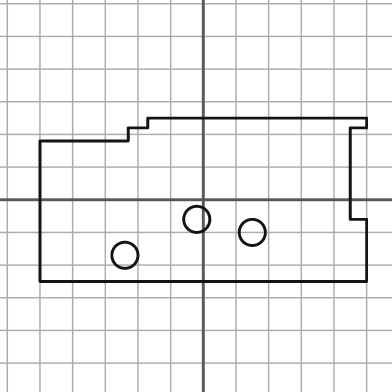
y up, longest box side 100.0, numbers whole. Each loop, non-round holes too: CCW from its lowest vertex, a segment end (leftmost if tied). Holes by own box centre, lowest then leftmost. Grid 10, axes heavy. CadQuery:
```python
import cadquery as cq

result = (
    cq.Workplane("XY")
    .moveTo(-50.0, -25.0)
    .lineTo(50.0, -25.0)
    .lineTo(50.0, -6.0)
    .lineTo(45.0, -6.0)
    .lineTo(45.0, 22.0)
    .lineTo(50.0, 22.0)
    .lineTo(50.0, 25.0)
    .lineTo(-17.0, 25.0)
    .lineTo(-17.0, 22.0)
    .lineTo(-23.0, 22.0)
    .lineTo(-23.0, 18.0)
    .lineTo(-50.0, 18.0)
    .close()
    .moveTo(-24.0, -17.0)
    .circle(4.0)
    .moveTo(15.0, -10.0)
    .circle(4.0)
    .moveTo(-2.0, -6.0)
    .circle(4.0)
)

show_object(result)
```